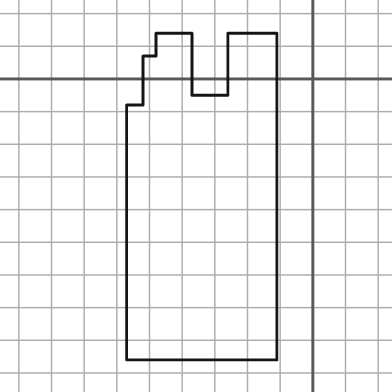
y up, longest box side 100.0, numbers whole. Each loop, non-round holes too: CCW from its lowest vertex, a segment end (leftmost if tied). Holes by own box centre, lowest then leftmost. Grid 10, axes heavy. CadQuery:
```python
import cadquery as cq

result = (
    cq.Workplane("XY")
    .moveTo(-57.0, -86.0)
    .lineTo(-11.0, -86.0)
    .lineTo(-11.0, 14.0)
    .lineTo(-26.0, 14.0)
    .lineTo(-26.0, -5.0)
    .lineTo(-37.0, -5.0)
    .lineTo(-37.0, 14.0)
    .lineTo(-48.0, 14.0)
    .lineTo(-48.0, 7.0)
    .lineTo(-52.0, 7.0)
    .lineTo(-52.0, -8.0)
    .lineTo(-57.0, -8.0)
    .close()
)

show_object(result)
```